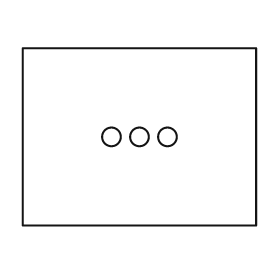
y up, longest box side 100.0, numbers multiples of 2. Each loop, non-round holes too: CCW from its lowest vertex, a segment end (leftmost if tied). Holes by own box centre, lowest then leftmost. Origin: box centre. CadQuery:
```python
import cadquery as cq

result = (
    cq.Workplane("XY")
    .moveTo(-50.0, -38.0)
    .lineTo(50.0, -38.0)
    .lineTo(50.0, 38.0)
    .lineTo(-50.0, 38.0)
    .close()
    .moveTo(-12.0, 0.0)
    .circle(4.0)
    .moveTo(0.0, 0.0)
    .circle(4.0)
    .moveTo(12.0, 0.0)
    .circle(4.0)
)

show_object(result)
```